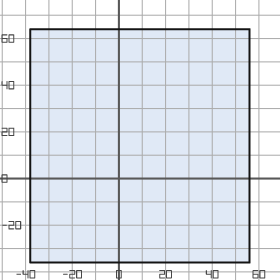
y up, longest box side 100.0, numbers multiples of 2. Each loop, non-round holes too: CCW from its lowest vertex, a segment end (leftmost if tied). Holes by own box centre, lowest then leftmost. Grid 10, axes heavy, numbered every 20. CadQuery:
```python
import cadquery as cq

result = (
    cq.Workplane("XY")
    .moveTo(-38.0, -36.0)
    .lineTo(56.0, -36.0)
    .lineTo(56.0, 64.0)
    .lineTo(-38.0, 64.0)
    .close()
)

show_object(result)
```